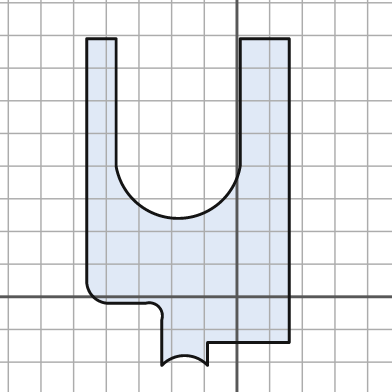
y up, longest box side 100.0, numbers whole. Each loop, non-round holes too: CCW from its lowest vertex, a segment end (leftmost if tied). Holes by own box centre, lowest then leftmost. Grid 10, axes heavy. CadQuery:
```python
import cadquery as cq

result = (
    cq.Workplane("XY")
    .moveTo(-23.0, -21.0)
    .threePointArc((-16.0, -18.0), (-9.0, -21.0))
    .lineTo(-9.0, -14.0)
    .lineTo(16.0, -14.0)
    .lineTo(16.0, 79.0)
    .lineTo(1.0, 79.0)
    .lineTo(1.0, 40.0)
    .threePointArc((-18.0, 24.0), (-37.0, 40.0))
    .lineTo(-37.0, 79.0)
    .lineTo(-46.0, 79.0)
    .lineTo(-46.0, 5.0)
    .threePointArc((-44.0, 0.0), (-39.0, -2.0))
    .lineTo(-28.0, -2.0)
    .threePointArc((-24.0, -3.0), (-23.0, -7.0))
    .close()
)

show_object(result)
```